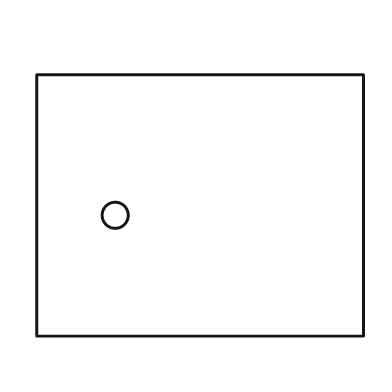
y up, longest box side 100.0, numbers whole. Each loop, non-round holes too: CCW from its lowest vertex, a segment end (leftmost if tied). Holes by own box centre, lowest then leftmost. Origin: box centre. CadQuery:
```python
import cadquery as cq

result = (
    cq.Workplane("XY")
    .moveTo(-50.0, -40.0)
    .lineTo(50.0, -40.0)
    .lineTo(50.0, 40.0)
    .lineTo(-50.0, 40.0)
    .close()
    .moveTo(-26.0, -3.0)
    .circle(4.0)
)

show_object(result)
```